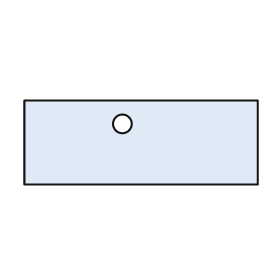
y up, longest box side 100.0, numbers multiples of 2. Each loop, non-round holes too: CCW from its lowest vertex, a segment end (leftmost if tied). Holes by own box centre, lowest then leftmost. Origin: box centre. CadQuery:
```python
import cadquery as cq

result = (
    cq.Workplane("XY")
    .moveTo(-50.0, -18.0)
    .lineTo(50.0, -18.0)
    .lineTo(50.0, 18.0)
    .lineTo(-50.0, 18.0)
    .close()
    .moveTo(-8.0, 8.0)
    .circle(4.0)
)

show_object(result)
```